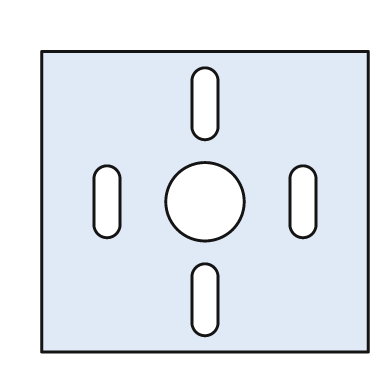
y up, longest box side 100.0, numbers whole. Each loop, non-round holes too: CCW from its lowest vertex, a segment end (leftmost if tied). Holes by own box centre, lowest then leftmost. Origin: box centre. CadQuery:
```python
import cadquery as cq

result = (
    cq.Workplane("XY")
    .moveTo(-50.0, -46.0)
    .lineTo(50.0, -46.0)
    .lineTo(50.0, 46.0)
    .lineTo(-50.0, 46.0)
    .close()
    .moveTo(-4.0, -37.0)
    .threePointArc((0.0, -41.0), (4.0, -37.0))
    .lineTo(4.0, -23.0)
    .threePointArc((0.0, -19.0), (-4.0, -23.0))
    .close()
    .moveTo(-34.0, -7.0)
    .threePointArc((-30.0, -11.0), (-26.0, -7.0))
    .lineTo(-26.0, 7.0)
    .threePointArc((-30.0, 11.0), (-34.0, 7.0))
    .close()
    .moveTo(0.0, 0.0)
    .circle(12.0)
    .moveTo(26.0, -7.0)
    .threePointArc((30.0, -11.0), (34.0, -7.0))
    .lineTo(34.0, 7.0)
    .threePointArc((30.0, 11.0), (26.0, 7.0))
    .close()
    .moveTo(-4.0, 23.0)
    .threePointArc((0.0, 19.0), (4.0, 23.0))
    .lineTo(4.0, 37.0)
    .threePointArc((0.0, 41.0), (-4.0, 37.0))
    .close()
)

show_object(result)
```